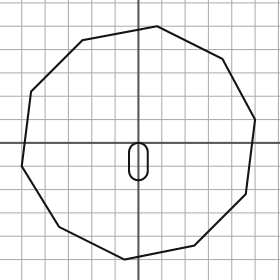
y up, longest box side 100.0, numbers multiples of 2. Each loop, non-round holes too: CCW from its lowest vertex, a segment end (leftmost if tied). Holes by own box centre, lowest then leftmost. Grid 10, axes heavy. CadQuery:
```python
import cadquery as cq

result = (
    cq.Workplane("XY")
    .moveTo(-6.0, -50.0)
    .lineTo(24.0, -44.0)
    .lineTo(46.0, -22.0)
    .lineTo(50.0, 10.0)
    .lineTo(36.0, 36.0)
    .lineTo(8.0, 50.0)
    .lineTo(-24.0, 44.0)
    .lineTo(-46.0, 22.0)
    .lineTo(-50.0, -10.0)
    .lineTo(-34.0, -36.0)
    .close()
    .moveTo(-4.0, -12.0)
    .threePointArc((0.0, -16.0), (4.0, -12.0))
    .lineTo(4.0, -4.0)
    .threePointArc((0.0, 0.0), (-4.0, -4.0))
    .close()
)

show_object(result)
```